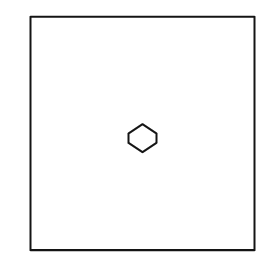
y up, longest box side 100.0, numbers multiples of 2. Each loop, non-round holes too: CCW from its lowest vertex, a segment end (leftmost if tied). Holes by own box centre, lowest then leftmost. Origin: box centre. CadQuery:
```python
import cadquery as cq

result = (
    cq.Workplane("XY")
    .moveTo(-48.0, -50.0)
    .lineTo(48.0, -50.0)
    .lineTo(48.0, 50.0)
    .lineTo(-48.0, 50.0)
    .close()
    .moveTo(0.0, -8.0)
    .lineTo(6.0, -4.0)
    .lineTo(6.0, 0.0)
    .lineTo(0.0, 4.0)
    .lineTo(-6.0, 0.0)
    .lineTo(-6.0, -4.0)
    .close()
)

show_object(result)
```